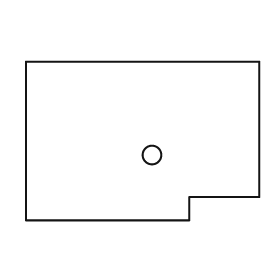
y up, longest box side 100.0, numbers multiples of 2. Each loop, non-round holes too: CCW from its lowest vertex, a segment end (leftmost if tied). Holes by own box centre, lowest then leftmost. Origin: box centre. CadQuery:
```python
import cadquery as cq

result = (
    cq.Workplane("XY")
    .moveTo(-50.0, -34.0)
    .lineTo(20.0, -34.0)
    .lineTo(20.0, -24.0)
    .lineTo(50.0, -24.0)
    .lineTo(50.0, 34.0)
    .lineTo(-50.0, 34.0)
    .close()
    .moveTo(4.0, -6.0)
    .circle(4.0)
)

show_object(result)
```